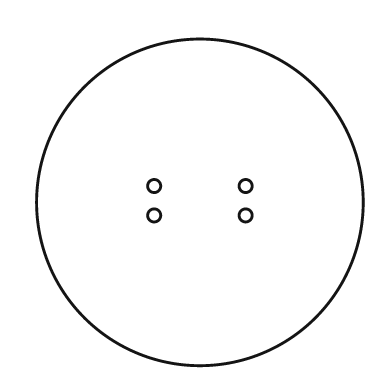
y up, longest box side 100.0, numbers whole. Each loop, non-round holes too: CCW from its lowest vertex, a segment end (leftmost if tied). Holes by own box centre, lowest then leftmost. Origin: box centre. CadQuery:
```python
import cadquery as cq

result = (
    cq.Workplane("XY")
    .moveTo(0.0, 0.0)
    .circle(50.0)
    .moveTo(-14.0, -4.0)
    .circle(2.0)
    .moveTo(14.0, -4.0)
    .circle(2.0)
    .moveTo(-14.0, 5.0)
    .circle(2.0)
    .moveTo(14.0, 5.0)
    .circle(2.0)
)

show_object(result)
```